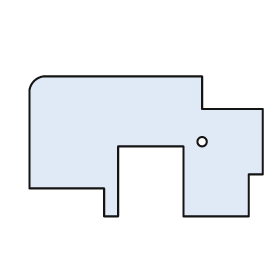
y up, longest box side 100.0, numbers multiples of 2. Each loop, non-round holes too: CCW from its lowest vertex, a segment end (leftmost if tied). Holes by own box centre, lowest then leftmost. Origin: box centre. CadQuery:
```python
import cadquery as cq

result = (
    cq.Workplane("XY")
    .moveTo(-18.0, -30.0)
    .lineTo(-12.0, -30.0)
    .lineTo(-12.0, 0.0)
    .lineTo(16.0, 0.0)
    .lineTo(16.0, -30.0)
    .lineTo(44.0, -30.0)
    .lineTo(44.0, -12.0)
    .lineTo(50.0, -12.0)
    .lineTo(50.0, 16.0)
    .lineTo(24.0, 16.0)
    .lineTo(24.0, 30.0)
    .lineTo(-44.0, 30.0)
    .threePointArc((-48.0, 28.0), (-50.0, 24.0))
    .lineTo(-50.0, -18.0)
    .lineTo(-18.0, -18.0)
    .close()
    .moveTo(24.0, 2.0)
    .circle(2.0)
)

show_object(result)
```